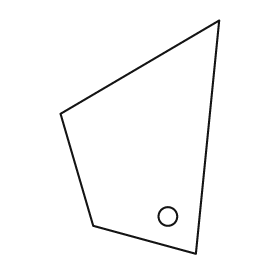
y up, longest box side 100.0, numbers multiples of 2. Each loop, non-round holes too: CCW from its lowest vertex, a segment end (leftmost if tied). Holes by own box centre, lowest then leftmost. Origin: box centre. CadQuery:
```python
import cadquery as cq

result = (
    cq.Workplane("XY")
    .moveTo(24.0, -50.0)
    .lineTo(34.0, 50.0)
    .lineTo(-34.0, 10.0)
    .lineTo(-20.0, -38.0)
    .close()
    .moveTo(12.0, -34.0)
    .circle(4.0)
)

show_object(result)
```